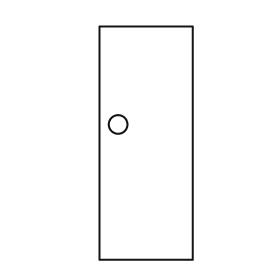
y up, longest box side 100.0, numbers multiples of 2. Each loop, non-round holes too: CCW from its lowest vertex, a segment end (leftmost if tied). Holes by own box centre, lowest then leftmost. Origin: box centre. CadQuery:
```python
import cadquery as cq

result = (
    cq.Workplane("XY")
    .moveTo(-20.0, -50.0)
    .lineTo(20.0, -50.0)
    .lineTo(20.0, 50.0)
    .lineTo(-20.0, 50.0)
    .close()
    .moveTo(-12.0, 8.0)
    .circle(4.0)
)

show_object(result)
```